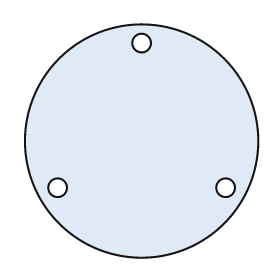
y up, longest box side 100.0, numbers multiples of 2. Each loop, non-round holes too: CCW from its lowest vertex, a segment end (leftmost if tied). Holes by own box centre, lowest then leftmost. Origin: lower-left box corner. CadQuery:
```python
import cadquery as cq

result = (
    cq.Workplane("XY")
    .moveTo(50.0, 50.0)
    .circle(50.0)
    .moveTo(14.0, 30.0)
    .circle(4.0)
    .moveTo(86.0, 30.0)
    .circle(4.0)
    .moveTo(50.0, 92.0)
    .circle(4.0)
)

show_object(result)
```